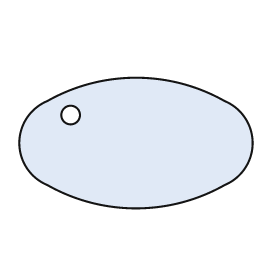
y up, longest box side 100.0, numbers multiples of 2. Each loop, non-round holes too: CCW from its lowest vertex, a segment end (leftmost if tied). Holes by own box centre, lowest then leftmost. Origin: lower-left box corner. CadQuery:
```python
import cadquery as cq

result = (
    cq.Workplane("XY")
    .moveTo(12.0, 10.0)
    .threePointArc((50.0, 0.0), (88.0, 10.0))
    .threePointArc((100.0, 28.0), (88.0, 46.0))
    .threePointArc((50.0, 56.0), (12.0, 46.0))
    .threePointArc((0.0, 28.0), (12.0, 10.0))
    .close()
    .moveTo(22.0, 40.0)
    .circle(4.0)
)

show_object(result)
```